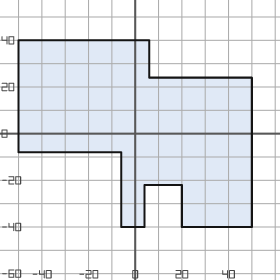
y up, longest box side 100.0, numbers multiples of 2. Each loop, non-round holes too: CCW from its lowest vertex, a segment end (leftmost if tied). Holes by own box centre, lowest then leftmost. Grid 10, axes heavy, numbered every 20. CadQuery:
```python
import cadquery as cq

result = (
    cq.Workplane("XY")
    .moveTo(-6.0, -40.0)
    .lineTo(4.0, -40.0)
    .lineTo(4.0, -22.0)
    .lineTo(20.0, -22.0)
    .lineTo(20.0, -40.0)
    .lineTo(50.0, -40.0)
    .lineTo(50.0, 24.0)
    .lineTo(6.0, 24.0)
    .lineTo(6.0, 40.0)
    .lineTo(-50.0, 40.0)
    .lineTo(-50.0, -8.0)
    .lineTo(-6.0, -8.0)
    .close()
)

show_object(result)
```